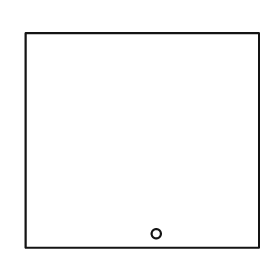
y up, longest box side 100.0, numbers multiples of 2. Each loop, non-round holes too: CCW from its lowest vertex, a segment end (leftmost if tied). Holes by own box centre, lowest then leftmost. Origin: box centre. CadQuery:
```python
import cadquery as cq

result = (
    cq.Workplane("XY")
    .moveTo(-50.0, -46.0)
    .lineTo(50.0, -46.0)
    .lineTo(50.0, 46.0)
    .lineTo(-50.0, 46.0)
    .close()
    .moveTo(6.0, -40.0)
    .circle(2.0)
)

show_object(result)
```